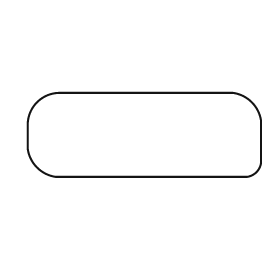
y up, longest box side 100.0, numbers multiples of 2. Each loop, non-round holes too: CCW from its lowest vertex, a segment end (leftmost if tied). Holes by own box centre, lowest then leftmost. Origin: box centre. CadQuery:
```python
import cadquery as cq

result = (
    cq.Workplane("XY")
    .moveTo(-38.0, -18.0)
    .lineTo(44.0, -18.0)
    .threePointArc((48.0, -16.0), (50.0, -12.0))
    .lineTo(50.0, 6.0)
    .threePointArc((46.0, 14.0), (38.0, 18.0))
    .lineTo(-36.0, 18.0)
    .threePointArc((-46.0, 14.0), (-50.0, 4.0))
    .lineTo(-50.0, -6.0)
    .threePointArc((-46.0, -14.0), (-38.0, -18.0))
    .close()
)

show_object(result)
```